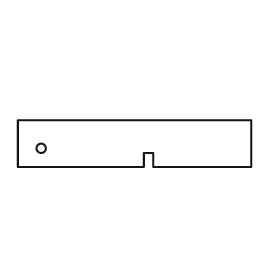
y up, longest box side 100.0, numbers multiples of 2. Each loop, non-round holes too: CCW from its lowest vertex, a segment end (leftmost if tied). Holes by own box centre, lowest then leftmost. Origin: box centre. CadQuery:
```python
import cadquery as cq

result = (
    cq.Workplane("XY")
    .moveTo(-50.0, -10.0)
    .lineTo(4.0, -10.0)
    .lineTo(4.0, -4.0)
    .lineTo(8.0, -4.0)
    .lineTo(8.0, -10.0)
    .lineTo(50.0, -10.0)
    .lineTo(50.0, 10.0)
    .lineTo(-50.0, 10.0)
    .close()
    .moveTo(-40.0, -2.0)
    .circle(2.0)
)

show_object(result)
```